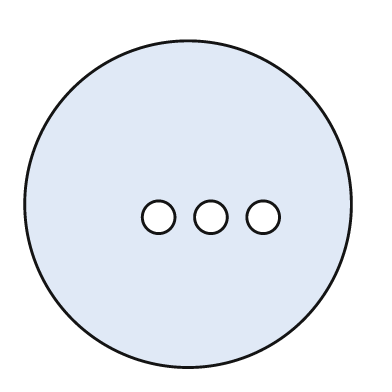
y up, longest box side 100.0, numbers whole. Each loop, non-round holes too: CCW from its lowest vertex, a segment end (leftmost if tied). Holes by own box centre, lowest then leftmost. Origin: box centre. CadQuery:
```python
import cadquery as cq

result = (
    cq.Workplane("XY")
    .moveTo(0.0, 0.0)
    .circle(50.0)
    .moveTo(-9.0, -4.0)
    .circle(5.0)
    .moveTo(7.0, -4.0)
    .circle(5.0)
    .moveTo(23.0, -4.0)
    .circle(5.0)
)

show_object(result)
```